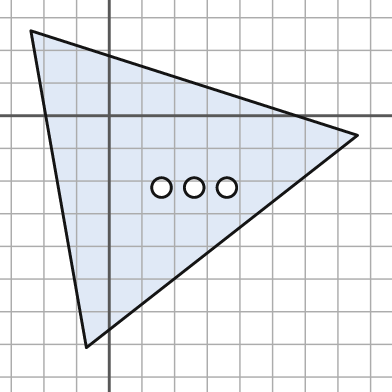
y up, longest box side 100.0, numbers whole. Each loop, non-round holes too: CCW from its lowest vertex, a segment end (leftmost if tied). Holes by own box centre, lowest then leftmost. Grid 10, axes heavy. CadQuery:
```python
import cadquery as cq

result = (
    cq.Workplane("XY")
    .moveTo(-7.0, -71.0)
    .lineTo(76.0, -6.0)
    .lineTo(-24.0, 26.0)
    .close()
    .moveTo(16.0, -22.0)
    .circle(3.0)
    .moveTo(26.0, -22.0)
    .circle(3.0)
    .moveTo(36.0, -22.0)
    .circle(3.0)
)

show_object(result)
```